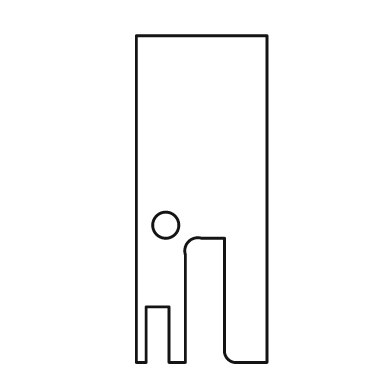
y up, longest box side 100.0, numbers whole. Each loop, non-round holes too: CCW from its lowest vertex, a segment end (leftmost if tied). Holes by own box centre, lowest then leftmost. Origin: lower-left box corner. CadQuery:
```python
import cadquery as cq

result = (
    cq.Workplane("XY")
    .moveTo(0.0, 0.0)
    .lineTo(3.0, 0.0)
    .lineTo(3.0, 17.0)
    .lineTo(10.0, 17.0)
    .lineTo(10.0, 0.0)
    .lineTo(15.0, 0.0)
    .lineTo(15.0, 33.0)
    .threePointArc((16.0, 37.0), (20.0, 38.0))
    .lineTo(27.0, 38.0)
    .lineTo(27.0, 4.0)
    .threePointArc((28.0, 1.0), (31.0, 0.0))
    .lineTo(40.0, 0.0)
    .lineTo(40.0, 100.0)
    .lineTo(0.0, 100.0)
    .close()
    .moveTo(9.0, 42.0)
    .circle(4.0)
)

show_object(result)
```